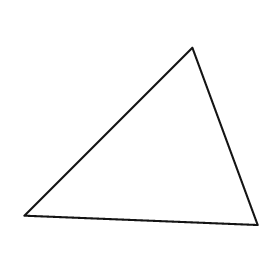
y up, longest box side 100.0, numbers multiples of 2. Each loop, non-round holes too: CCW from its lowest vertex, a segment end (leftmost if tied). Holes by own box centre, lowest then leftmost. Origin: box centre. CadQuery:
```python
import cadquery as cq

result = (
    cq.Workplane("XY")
    .moveTo(50.0, -38.0)
    .lineTo(22.0, 38.0)
    .lineTo(-50.0, -34.0)
    .close()
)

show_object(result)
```